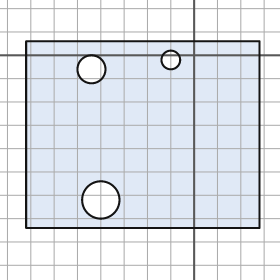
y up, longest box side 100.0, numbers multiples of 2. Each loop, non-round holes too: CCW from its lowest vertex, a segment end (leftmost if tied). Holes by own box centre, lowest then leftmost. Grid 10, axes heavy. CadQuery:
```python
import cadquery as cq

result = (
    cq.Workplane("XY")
    .moveTo(-72.0, -74.0)
    .lineTo(28.0, -74.0)
    .lineTo(28.0, 6.0)
    .lineTo(-72.0, 6.0)
    .close()
    .moveTo(-40.0, -62.0)
    .circle(8.0)
    .moveTo(-44.0, -6.0)
    .circle(6.0)
    .moveTo(-10.0, -2.0)
    .circle(4.0)
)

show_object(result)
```